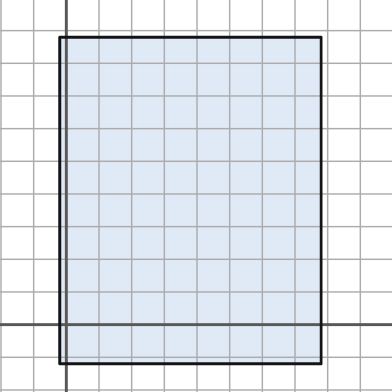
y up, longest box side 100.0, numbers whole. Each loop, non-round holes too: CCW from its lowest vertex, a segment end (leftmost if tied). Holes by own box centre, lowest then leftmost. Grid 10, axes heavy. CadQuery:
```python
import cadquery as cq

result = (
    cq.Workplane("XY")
    .moveTo(-2.0, -12.0)
    .lineTo(78.0, -12.0)
    .lineTo(78.0, 88.0)
    .lineTo(-2.0, 88.0)
    .close()
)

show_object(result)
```